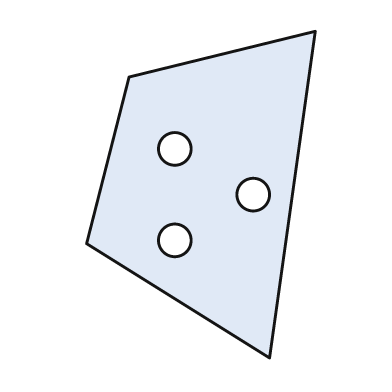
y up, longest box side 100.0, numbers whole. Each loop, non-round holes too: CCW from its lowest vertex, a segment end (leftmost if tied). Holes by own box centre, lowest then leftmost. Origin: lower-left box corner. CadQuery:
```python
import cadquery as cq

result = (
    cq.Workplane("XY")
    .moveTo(56.0, 0.0)
    .lineTo(70.0, 100.0)
    .lineTo(13.0, 86.0)
    .lineTo(0.0, 35.0)
    .close()
    .moveTo(27.0, 36.0)
    .circle(5.0)
    .moveTo(51.0, 50.0)
    .circle(5.0)
    .moveTo(27.0, 64.0)
    .circle(5.0)
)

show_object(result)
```